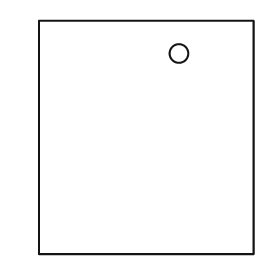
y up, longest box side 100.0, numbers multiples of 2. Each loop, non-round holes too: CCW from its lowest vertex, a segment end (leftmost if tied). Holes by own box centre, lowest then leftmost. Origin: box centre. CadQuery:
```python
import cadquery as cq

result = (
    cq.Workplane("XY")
    .moveTo(-46.0, -50.0)
    .lineTo(46.0, -50.0)
    .lineTo(46.0, 50.0)
    .lineTo(-46.0, 50.0)
    .close()
    .moveTo(14.0, 36.0)
    .circle(4.0)
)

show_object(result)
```